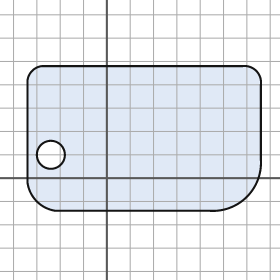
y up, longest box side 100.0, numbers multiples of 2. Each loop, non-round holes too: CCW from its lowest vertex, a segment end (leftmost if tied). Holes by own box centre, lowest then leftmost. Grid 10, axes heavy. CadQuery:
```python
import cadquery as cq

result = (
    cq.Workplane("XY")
    .moveTo(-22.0, -14.0)
    .lineTo(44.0, -14.0)
    .threePointArc((60.0, -8.0), (66.0, 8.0))
    .lineTo(66.0, 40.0)
    .threePointArc((64.0, 46.0), (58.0, 48.0))
    .lineTo(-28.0, 48.0)
    .threePointArc((-32.0, 46.0), (-34.0, 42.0))
    .lineTo(-34.0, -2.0)
    .threePointArc((-30.0, -10.0), (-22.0, -14.0))
    .close()
    .moveTo(-24.0, 10.0)
    .circle(6.0)
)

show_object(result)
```